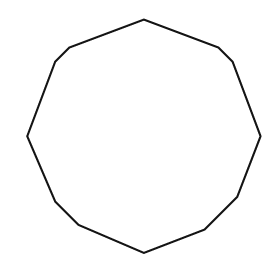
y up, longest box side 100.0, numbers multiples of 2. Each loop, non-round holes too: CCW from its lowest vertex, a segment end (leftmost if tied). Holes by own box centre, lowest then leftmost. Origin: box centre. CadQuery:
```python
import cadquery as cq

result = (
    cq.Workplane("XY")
    .moveTo(0.0, -50.0)
    .lineTo(26.0, -40.0)
    .lineTo(40.0, -26.0)
    .lineTo(50.0, 0.0)
    .lineTo(38.0, 32.0)
    .lineTo(32.0, 38.0)
    .lineTo(0.0, 50.0)
    .lineTo(-32.0, 38.0)
    .lineTo(-38.0, 32.0)
    .lineTo(-50.0, 0.0)
    .lineTo(-38.0, -28.0)
    .lineTo(-28.0, -38.0)
    .close()
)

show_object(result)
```